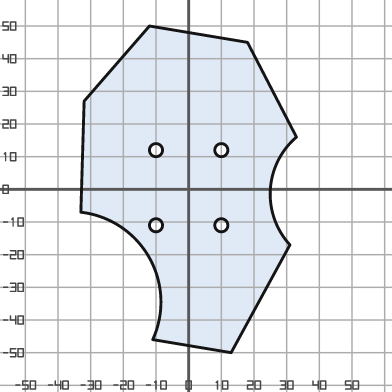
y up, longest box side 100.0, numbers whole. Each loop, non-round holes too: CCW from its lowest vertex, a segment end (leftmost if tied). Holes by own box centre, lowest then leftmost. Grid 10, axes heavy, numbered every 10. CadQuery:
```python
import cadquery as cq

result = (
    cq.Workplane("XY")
    .moveTo(13.0, -50.0)
    .lineTo(31.0, -17.0)
    .threePointArc((25.0, 0.0), (33.0, 16.0))
    .lineTo(18.0, 45.0)
    .lineTo(-12.0, 50.0)
    .lineTo(-32.0, 27.0)
    .lineTo(-33.0, -7.0)
    .threePointArc((-12.0, -21.0), (-11.0, -46.0))
    .close()
    .moveTo(-10.0, -11.0)
    .circle(2.0)
    .moveTo(10.0, -11.0)
    .circle(2.0)
    .moveTo(-10.0, 12.0)
    .circle(2.0)
    .moveTo(10.0, 12.0)
    .circle(2.0)
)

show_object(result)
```